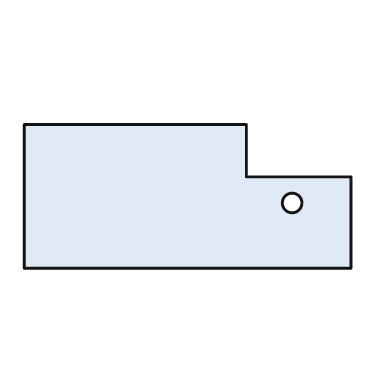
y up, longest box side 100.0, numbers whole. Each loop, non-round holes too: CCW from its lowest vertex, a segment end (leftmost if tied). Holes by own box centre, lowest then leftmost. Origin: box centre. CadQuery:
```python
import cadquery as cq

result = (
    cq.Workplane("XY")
    .moveTo(-50.0, -22.0)
    .lineTo(50.0, -22.0)
    .lineTo(50.0, 6.0)
    .lineTo(18.0, 6.0)
    .lineTo(18.0, 22.0)
    .lineTo(-50.0, 22.0)
    .close()
    .moveTo(32.0, -2.0)
    .circle(3.0)
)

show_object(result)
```